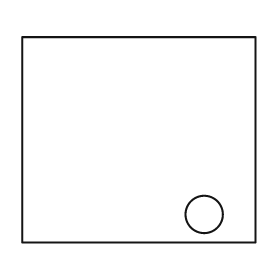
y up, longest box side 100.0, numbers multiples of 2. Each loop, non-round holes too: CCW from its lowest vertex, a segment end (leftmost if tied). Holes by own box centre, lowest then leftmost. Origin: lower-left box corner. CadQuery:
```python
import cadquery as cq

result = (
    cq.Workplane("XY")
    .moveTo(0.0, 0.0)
    .lineTo(100.0, 0.0)
    .lineTo(100.0, 88.0)
    .lineTo(0.0, 88.0)
    .close()
    .moveTo(78.0, 12.0)
    .circle(8.0)
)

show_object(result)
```